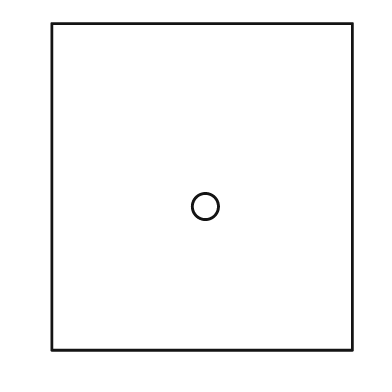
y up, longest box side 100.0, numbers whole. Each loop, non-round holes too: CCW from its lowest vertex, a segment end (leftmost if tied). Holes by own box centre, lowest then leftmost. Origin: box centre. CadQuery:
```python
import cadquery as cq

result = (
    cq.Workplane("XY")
    .moveTo(-46.0, -50.0)
    .lineTo(46.0, -50.0)
    .lineTo(46.0, 50.0)
    .lineTo(-46.0, 50.0)
    .close()
    .moveTo(1.0, -6.0)
    .circle(4.0)
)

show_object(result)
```